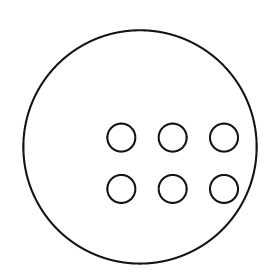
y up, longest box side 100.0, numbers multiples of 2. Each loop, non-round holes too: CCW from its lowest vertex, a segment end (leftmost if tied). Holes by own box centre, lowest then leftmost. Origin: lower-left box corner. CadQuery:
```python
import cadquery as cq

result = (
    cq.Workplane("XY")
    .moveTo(50.0, 50.0)
    .circle(50.0)
    .moveTo(42.0, 32.0)
    .circle(6.0)
    .moveTo(64.0, 32.0)
    .circle(6.0)
    .moveTo(86.0, 32.0)
    .circle(6.0)
    .moveTo(42.0, 54.0)
    .circle(6.0)
    .moveTo(64.0, 54.0)
    .circle(6.0)
    .moveTo(86.0, 54.0)
    .circle(6.0)
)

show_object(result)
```